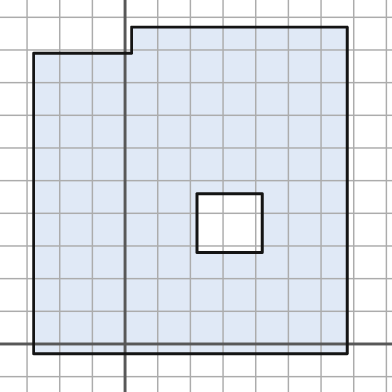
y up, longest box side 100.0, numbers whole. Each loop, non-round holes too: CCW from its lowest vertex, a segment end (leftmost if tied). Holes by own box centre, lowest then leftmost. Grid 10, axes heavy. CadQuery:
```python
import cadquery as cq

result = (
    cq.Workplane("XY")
    .moveTo(-28.0, -3.0)
    .lineTo(68.0, -3.0)
    .lineTo(68.0, 97.0)
    .lineTo(2.0, 97.0)
    .lineTo(2.0, 89.0)
    .lineTo(-28.0, 89.0)
    .close()
    .moveTo(22.0, 28.0)
    .lineTo(42.0, 28.0)
    .lineTo(42.0, 46.0)
    .lineTo(22.0, 46.0)
    .close()
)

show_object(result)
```